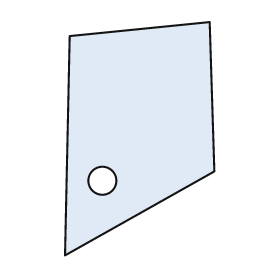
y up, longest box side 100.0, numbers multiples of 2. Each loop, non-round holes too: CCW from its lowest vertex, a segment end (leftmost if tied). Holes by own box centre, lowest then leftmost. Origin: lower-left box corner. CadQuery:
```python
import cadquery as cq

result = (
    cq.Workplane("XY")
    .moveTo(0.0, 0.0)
    .lineTo(64.0, 36.0)
    .lineTo(62.0, 100.0)
    .lineTo(2.0, 94.0)
    .close()
    .moveTo(16.0, 32.0)
    .circle(6.0)
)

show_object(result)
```